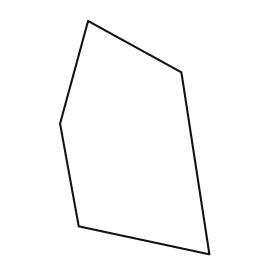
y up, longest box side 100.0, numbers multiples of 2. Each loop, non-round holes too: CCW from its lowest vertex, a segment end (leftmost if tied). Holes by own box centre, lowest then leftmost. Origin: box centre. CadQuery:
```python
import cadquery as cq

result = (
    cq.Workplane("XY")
    .moveTo(32.0, -50.0)
    .lineTo(20.0, 28.0)
    .lineTo(-20.0, 50.0)
    .lineTo(-32.0, 6.0)
    .lineTo(-24.0, -38.0)
    .close()
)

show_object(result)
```